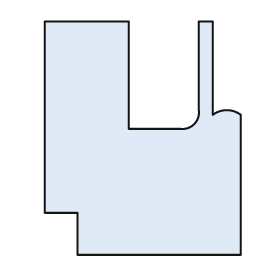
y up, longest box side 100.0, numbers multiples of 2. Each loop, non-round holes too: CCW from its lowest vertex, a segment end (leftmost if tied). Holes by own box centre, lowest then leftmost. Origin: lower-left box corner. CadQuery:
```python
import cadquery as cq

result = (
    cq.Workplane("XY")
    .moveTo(14.0, 0.0)
    .lineTo(84.0, 0.0)
    .lineTo(84.0, 60.0)
    .threePointArc((78.0, 62.0), (72.0, 60.0))
    .lineTo(72.0, 100.0)
    .lineTo(66.0, 100.0)
    .lineTo(66.0, 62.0)
    .threePointArc((64.0, 56.0), (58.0, 54.0))
    .lineTo(36.0, 54.0)
    .lineTo(36.0, 100.0)
    .lineTo(0.0, 100.0)
    .lineTo(0.0, 18.0)
    .lineTo(14.0, 18.0)
    .close()
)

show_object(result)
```